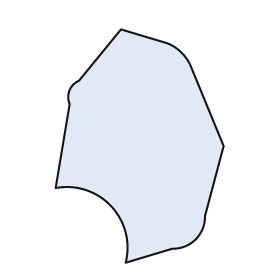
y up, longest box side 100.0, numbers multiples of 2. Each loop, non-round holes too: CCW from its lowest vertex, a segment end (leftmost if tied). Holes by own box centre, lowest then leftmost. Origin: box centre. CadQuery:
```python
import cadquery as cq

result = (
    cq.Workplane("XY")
    .moveTo(-6.0, -50.0)
    .lineTo(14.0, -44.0)
    .threePointArc((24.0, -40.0), (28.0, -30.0))
    .lineTo(36.0, 0.0)
    .lineTo(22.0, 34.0)
    .threePointArc((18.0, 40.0), (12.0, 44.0))
    .lineTo(-8.0, 50.0)
    .lineTo(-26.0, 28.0)
    .threePointArc((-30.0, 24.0), (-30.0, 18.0))
    .lineTo(-36.0, -18.0)
    .threePointArc((-12.0, -26.0), (-6.0, -50.0))
    .close()
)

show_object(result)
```